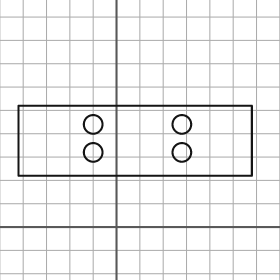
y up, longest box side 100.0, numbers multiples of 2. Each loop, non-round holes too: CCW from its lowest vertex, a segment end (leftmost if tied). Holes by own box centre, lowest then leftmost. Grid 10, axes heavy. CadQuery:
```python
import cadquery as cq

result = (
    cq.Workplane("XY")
    .moveTo(-42.0, 22.0)
    .lineTo(58.0, 22.0)
    .lineTo(58.0, 52.0)
    .lineTo(-42.0, 52.0)
    .close()
    .moveTo(-10.0, 32.0)
    .circle(4.0)
    .moveTo(28.0, 32.0)
    .circle(4.0)
    .moveTo(-10.0, 44.0)
    .circle(4.0)
    .moveTo(28.0, 44.0)
    .circle(4.0)
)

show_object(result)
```